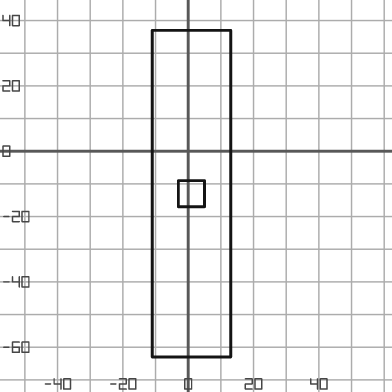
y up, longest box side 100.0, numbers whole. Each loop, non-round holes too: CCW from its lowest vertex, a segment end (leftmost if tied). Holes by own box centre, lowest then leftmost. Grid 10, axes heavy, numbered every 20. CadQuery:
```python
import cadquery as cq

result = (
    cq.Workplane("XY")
    .moveTo(-11.0, -63.0)
    .lineTo(13.0, -63.0)
    .lineTo(13.0, 37.0)
    .lineTo(-11.0, 37.0)
    .close()
    .moveTo(-3.0, -17.0)
    .lineTo(5.0, -17.0)
    .lineTo(5.0, -9.0)
    .lineTo(-3.0, -9.0)
    .close()
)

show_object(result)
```